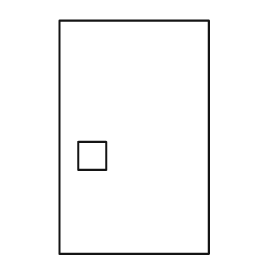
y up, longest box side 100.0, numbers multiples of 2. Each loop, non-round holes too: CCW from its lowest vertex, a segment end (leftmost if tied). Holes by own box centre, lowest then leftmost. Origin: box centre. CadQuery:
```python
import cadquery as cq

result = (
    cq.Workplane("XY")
    .moveTo(-32.0, -50.0)
    .lineTo(32.0, -50.0)
    .lineTo(32.0, 50.0)
    .lineTo(-32.0, 50.0)
    .close()
    .moveTo(-24.0, -14.0)
    .lineTo(-12.0, -14.0)
    .lineTo(-12.0, -2.0)
    .lineTo(-24.0, -2.0)
    .close()
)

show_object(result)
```